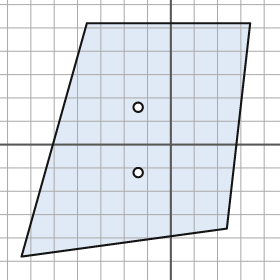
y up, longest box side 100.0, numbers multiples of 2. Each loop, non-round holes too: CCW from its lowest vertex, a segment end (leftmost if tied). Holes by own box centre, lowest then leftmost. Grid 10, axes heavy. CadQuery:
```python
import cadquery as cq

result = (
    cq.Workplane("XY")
    .moveTo(-64.0, -48.0)
    .lineTo(24.0, -36.0)
    .lineTo(34.0, 52.0)
    .lineTo(-36.0, 52.0)
    .close()
    .moveTo(-14.0, -12.0)
    .circle(2.0)
    .moveTo(-14.0, 16.0)
    .circle(2.0)
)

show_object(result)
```